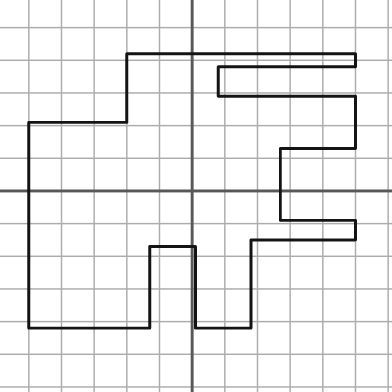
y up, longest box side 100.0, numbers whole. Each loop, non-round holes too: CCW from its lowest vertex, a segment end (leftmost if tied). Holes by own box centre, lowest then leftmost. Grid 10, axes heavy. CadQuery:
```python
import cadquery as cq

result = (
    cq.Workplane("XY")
    .moveTo(-50.0, -42.0)
    .lineTo(-13.0, -42.0)
    .lineTo(-13.0, -17.0)
    .lineTo(1.0, -17.0)
    .lineTo(1.0, -42.0)
    .lineTo(18.0, -42.0)
    .lineTo(18.0, -15.0)
    .lineTo(50.0, -15.0)
    .lineTo(50.0, -9.0)
    .lineTo(27.0, -9.0)
    .lineTo(27.0, 13.0)
    .lineTo(50.0, 13.0)
    .lineTo(50.0, 29.0)
    .lineTo(8.0, 29.0)
    .lineTo(8.0, 38.0)
    .lineTo(50.0, 38.0)
    .lineTo(50.0, 42.0)
    .lineTo(-20.0, 42.0)
    .lineTo(-20.0, 21.0)
    .lineTo(-50.0, 21.0)
    .close()
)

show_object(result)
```